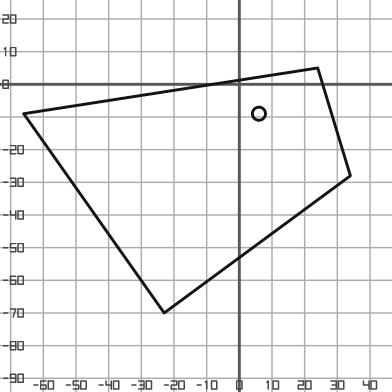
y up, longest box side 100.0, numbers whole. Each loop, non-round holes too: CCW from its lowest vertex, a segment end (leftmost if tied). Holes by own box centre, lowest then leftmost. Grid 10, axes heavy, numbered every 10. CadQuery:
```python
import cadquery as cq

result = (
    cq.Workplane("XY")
    .moveTo(-23.0, -70.0)
    .lineTo(34.0, -28.0)
    .lineTo(24.0, 5.0)
    .lineTo(-66.0, -9.0)
    .close()
    .moveTo(6.0, -9.0)
    .circle(2.0)
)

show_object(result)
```